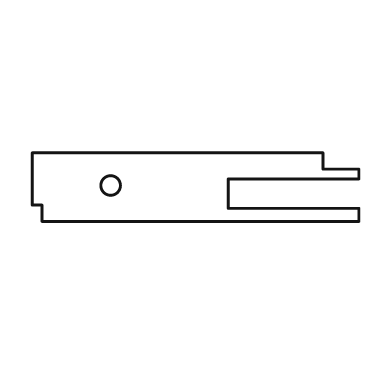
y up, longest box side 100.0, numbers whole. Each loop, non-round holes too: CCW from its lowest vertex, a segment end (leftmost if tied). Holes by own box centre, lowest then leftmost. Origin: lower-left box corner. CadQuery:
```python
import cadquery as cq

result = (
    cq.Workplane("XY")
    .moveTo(3.0, 0.0)
    .lineTo(100.0, 0.0)
    .lineTo(100.0, 4.0)
    .lineTo(60.0, 4.0)
    .lineTo(60.0, 13.0)
    .lineTo(100.0, 13.0)
    .lineTo(100.0, 16.0)
    .lineTo(89.0, 16.0)
    .lineTo(89.0, 21.0)
    .lineTo(0.0, 21.0)
    .lineTo(0.0, 5.0)
    .lineTo(3.0, 5.0)
    .close()
    .moveTo(24.0, 11.0)
    .circle(3.0)
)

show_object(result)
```